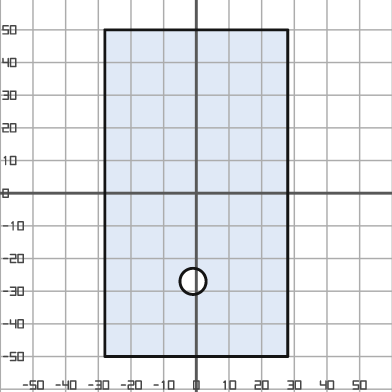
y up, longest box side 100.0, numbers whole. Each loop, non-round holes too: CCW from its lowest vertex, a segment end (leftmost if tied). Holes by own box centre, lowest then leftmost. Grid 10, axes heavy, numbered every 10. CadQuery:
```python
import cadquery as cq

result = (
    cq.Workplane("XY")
    .moveTo(-28.0, -50.0)
    .lineTo(28.0, -50.0)
    .lineTo(28.0, 50.0)
    .lineTo(-28.0, 50.0)
    .close()
    .moveTo(-1.0, -27.0)
    .circle(4.0)
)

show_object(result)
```